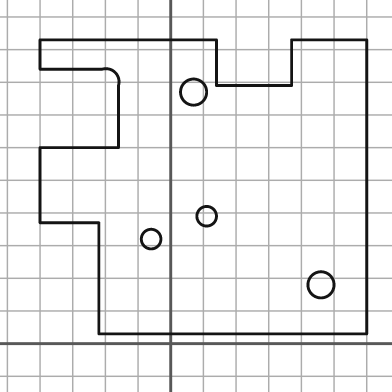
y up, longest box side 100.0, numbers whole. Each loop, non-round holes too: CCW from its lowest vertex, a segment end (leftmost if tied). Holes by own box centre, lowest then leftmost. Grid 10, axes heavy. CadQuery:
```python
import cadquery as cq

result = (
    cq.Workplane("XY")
    .moveTo(-22.0, 3.0)
    .lineTo(60.0, 3.0)
    .lineTo(60.0, 93.0)
    .lineTo(37.0, 93.0)
    .lineTo(37.0, 79.0)
    .lineTo(14.0, 79.0)
    .lineTo(14.0, 93.0)
    .lineTo(-40.0, 93.0)
    .lineTo(-40.0, 84.0)
    .lineTo(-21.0, 84.0)
    .threePointArc((-17.0, 83.0), (-16.0, 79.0))
    .lineTo(-16.0, 60.0)
    .lineTo(-40.0, 60.0)
    .lineTo(-40.0, 37.0)
    .lineTo(-22.0, 37.0)
    .close()
    .moveTo(46.0, 18.0)
    .circle(4.0)
    .moveTo(-6.0, 32.0)
    .circle(3.0)
    .moveTo(11.0, 39.0)
    .circle(3.0)
    .moveTo(7.0, 77.0)
    .circle(4.0)
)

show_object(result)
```